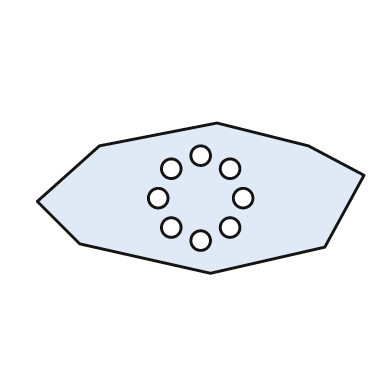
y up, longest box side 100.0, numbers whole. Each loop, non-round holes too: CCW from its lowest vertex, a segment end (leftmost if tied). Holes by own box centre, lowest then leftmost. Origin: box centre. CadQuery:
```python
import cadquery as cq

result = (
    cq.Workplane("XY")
    .moveTo(3.0, -23.0)
    .lineTo(38.0, -15.0)
    .lineTo(50.0, 7.0)
    .lineTo(33.0, 16.0)
    .lineTo(5.0, 23.0)
    .lineTo(-31.0, 16.0)
    .lineTo(-50.0, -1.0)
    .lineTo(-37.0, -14.0)
    .close()
    .moveTo(0.0, -13.0)
    .circle(3.0)
    .moveTo(-9.0, -9.0)
    .circle(3.0)
    .moveTo(9.0, -9.0)
    .circle(3.0)
    .moveTo(-13.0, 0.0)
    .circle(3.0)
    .moveTo(13.0, 0.0)
    .circle(3.0)
    .moveTo(-9.0, 9.0)
    .circle(3.0)
    .moveTo(9.0, 9.0)
    .circle(3.0)
    .moveTo(0.0, 13.0)
    .circle(3.0)
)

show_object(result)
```